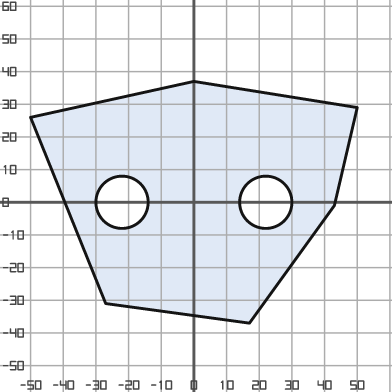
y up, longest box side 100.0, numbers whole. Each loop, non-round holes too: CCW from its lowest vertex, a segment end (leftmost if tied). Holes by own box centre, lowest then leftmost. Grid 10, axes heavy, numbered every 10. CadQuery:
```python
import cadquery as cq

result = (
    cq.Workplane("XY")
    .moveTo(17.0, -37.0)
    .lineTo(43.0, -1.0)
    .lineTo(50.0, 29.0)
    .lineTo(0.0, 37.0)
    .lineTo(-50.0, 26.0)
    .lineTo(-27.0, -31.0)
    .close()
    .moveTo(-22.0, 0.0)
    .circle(8.0)
    .moveTo(22.0, 0.0)
    .circle(8.0)
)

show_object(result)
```